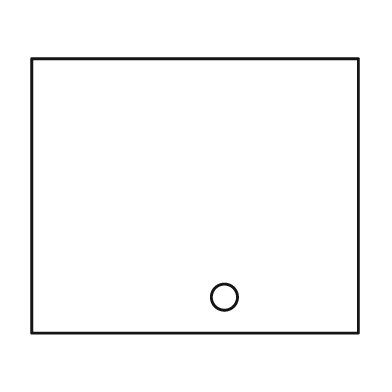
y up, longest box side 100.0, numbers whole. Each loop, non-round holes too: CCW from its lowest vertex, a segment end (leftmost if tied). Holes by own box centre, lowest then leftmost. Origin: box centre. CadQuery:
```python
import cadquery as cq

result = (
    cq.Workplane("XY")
    .moveTo(-50.0, -42.0)
    .lineTo(50.0, -42.0)
    .lineTo(50.0, 42.0)
    .lineTo(-50.0, 42.0)
    .close()
    .moveTo(9.0, -31.0)
    .circle(4.0)
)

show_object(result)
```